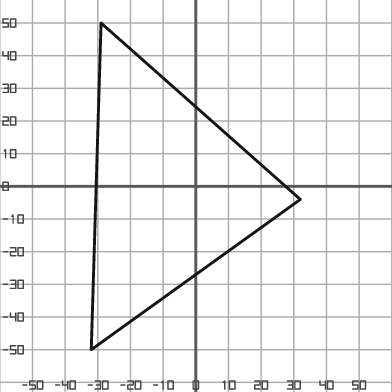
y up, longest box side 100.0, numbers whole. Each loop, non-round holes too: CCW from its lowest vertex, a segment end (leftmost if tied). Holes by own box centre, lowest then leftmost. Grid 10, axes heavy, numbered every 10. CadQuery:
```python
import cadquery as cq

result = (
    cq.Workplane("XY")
    .moveTo(-32.0, -50.0)
    .lineTo(32.0, -4.0)
    .lineTo(-29.0, 50.0)
    .close()
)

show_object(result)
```